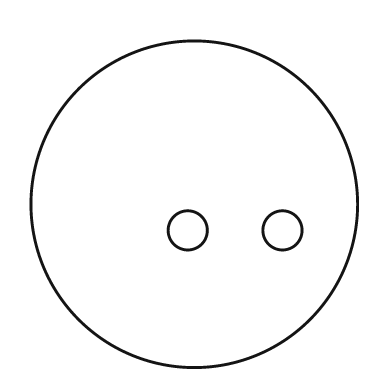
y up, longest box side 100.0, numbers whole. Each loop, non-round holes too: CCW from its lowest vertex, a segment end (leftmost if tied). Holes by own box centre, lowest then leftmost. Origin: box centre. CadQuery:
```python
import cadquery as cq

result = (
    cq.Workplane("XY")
    .moveTo(0.0, 0.0)
    .circle(50.0)
    .moveTo(-2.0, -8.0)
    .circle(6.0)
    .moveTo(27.0, -8.0)
    .circle(6.0)
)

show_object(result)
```